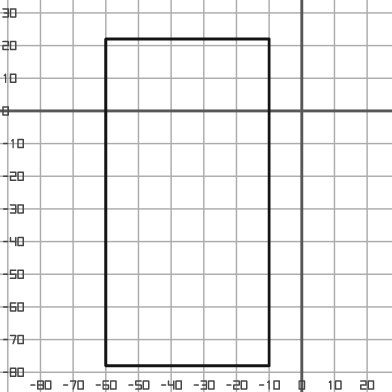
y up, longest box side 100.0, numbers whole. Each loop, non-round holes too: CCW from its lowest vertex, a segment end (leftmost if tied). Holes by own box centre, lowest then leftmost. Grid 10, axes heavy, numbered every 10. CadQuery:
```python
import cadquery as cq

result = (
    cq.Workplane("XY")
    .moveTo(-60.0, -78.0)
    .lineTo(-10.0, -78.0)
    .lineTo(-10.0, 22.0)
    .lineTo(-60.0, 22.0)
    .close()
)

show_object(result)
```